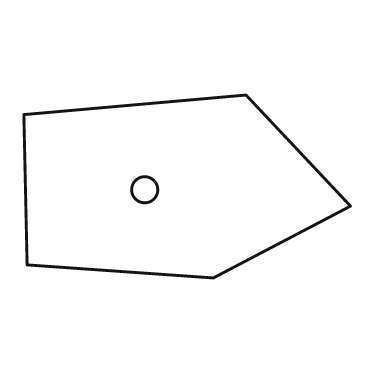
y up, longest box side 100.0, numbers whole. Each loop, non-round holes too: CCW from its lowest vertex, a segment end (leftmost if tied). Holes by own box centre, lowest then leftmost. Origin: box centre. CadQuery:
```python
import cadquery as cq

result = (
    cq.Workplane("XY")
    .moveTo(8.0, -28.0)
    .lineTo(50.0, -6.0)
    .lineTo(18.0, 28.0)
    .lineTo(-50.0, 22.0)
    .lineTo(-49.0, -24.0)
    .close()
    .moveTo(-13.0, -1.0)
    .circle(4.0)
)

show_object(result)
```